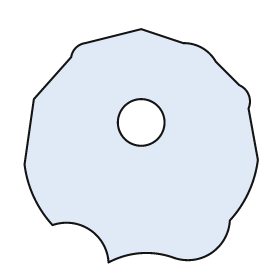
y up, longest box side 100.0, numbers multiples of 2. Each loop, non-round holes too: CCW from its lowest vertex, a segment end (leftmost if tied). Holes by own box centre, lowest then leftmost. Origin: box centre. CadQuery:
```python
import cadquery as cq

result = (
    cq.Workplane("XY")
    .moveTo(-14.0, -50.0)
    .threePointArc((0.0, -46.0), (14.0, -48.0))
    .threePointArc((30.0, -46.0), (38.0, -32.0))
    .threePointArc((46.0, -20.0), (50.0, -6.0))
    .lineTo(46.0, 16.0)
    .threePointArc((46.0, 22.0), (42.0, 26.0))
    .lineTo(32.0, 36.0)
    .threePointArc((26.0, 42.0), (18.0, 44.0))
    .lineTo(0.0, 50.0)
    .lineTo(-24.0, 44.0)
    .threePointArc((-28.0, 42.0), (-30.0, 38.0))
    .lineTo(-46.0, 20.0)
    .lineTo(-50.0, -8.0)
    .threePointArc((-46.0, -22.0), (-38.0, -34.0))
    .threePointArc((-22.0, -36.0), (-14.0, -50.0))
    .close()
    .moveTo(0.0, 10.0)
    .circle(10.0)
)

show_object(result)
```